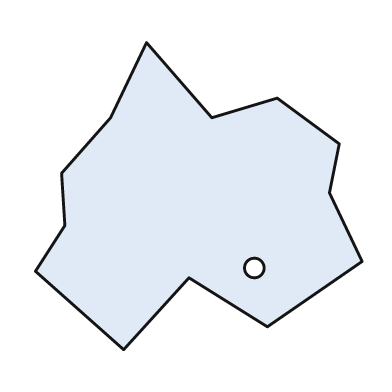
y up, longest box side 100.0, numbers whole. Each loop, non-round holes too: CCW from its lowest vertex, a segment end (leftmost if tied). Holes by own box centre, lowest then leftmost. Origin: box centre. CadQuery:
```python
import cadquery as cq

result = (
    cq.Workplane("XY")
    .moveTo(-23.0, -47.0)
    .lineTo(-3.0, -25.0)
    .lineTo(21.0, -40.0)
    .lineTo(50.0, -20.0)
    .lineTo(40.0, 1.0)
    .lineTo(43.0, 16.0)
    .lineTo(24.0, 30.0)
    .lineTo(4.0, 24.0)
    .lineTo(-16.0, 47.0)
    .lineTo(-27.0, 24.0)
    .lineTo(-42.0, 7.0)
    .lineTo(-41.0, -9.0)
    .lineTo(-50.0, -23.0)
    .close()
    .moveTo(17.0, -22.0)
    .circle(3.0)
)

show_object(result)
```